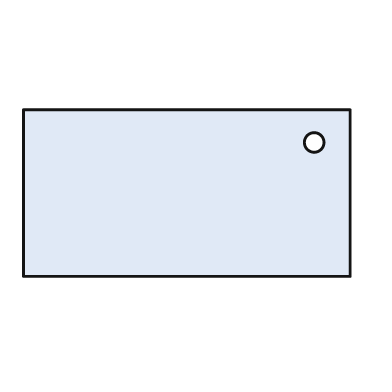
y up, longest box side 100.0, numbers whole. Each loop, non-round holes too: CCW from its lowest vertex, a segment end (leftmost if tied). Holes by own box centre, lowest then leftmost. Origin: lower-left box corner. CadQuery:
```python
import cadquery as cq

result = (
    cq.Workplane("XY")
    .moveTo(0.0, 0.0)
    .lineTo(100.0, 0.0)
    .lineTo(100.0, 51.0)
    .lineTo(0.0, 51.0)
    .close()
    .moveTo(89.0, 41.0)
    .circle(3.0)
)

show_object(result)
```